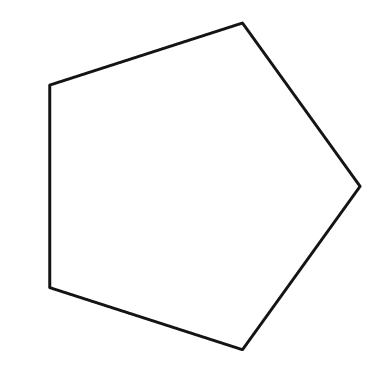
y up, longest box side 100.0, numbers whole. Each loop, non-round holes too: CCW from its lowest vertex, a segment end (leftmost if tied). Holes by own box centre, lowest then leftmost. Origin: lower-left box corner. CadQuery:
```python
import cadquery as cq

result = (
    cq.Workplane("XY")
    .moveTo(59.0, 0.0)
    .lineTo(95.0, 50.0)
    .lineTo(59.0, 100.0)
    .lineTo(0.0, 81.0)
    .lineTo(0.0, 19.0)
    .close()
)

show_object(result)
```